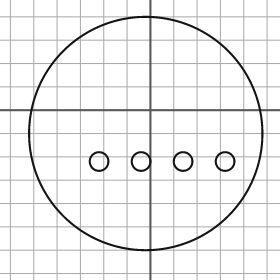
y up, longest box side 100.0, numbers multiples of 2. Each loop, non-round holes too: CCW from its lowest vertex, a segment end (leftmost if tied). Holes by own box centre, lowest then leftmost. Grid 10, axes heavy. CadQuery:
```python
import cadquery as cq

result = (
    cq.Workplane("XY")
    .moveTo(-2.0, -10.0)
    .circle(50.0)
    .moveTo(-22.0, -22.0)
    .circle(4.0)
    .moveTo(-4.0, -22.0)
    .circle(4.0)
    .moveTo(14.0, -22.0)
    .circle(4.0)
    .moveTo(32.0, -22.0)
    .circle(4.0)
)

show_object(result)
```